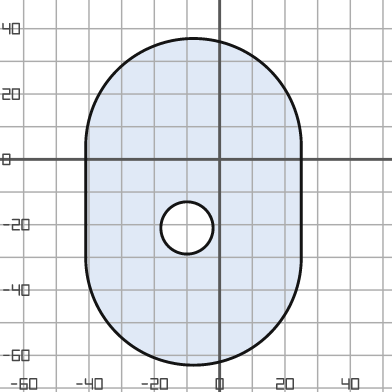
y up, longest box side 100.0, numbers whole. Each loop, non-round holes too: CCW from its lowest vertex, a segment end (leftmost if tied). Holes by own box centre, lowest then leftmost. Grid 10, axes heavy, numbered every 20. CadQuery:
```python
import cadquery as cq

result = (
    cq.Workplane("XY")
    .moveTo(-41.0, -30.0)
    .threePointArc((-8.0, -63.0), (25.0, -30.0))
    .lineTo(25.0, 4.0)
    .threePointArc((-8.0, 37.0), (-41.0, 4.0))
    .close()
    .moveTo(-10.0, -21.0)
    .circle(8.0)
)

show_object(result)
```